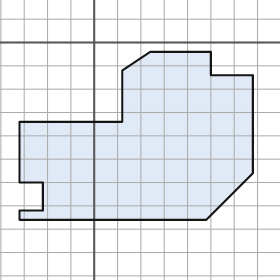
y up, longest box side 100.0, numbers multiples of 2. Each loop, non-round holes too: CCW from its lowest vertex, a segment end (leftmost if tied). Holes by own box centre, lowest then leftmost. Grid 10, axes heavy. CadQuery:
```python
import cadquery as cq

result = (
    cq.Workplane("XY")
    .moveTo(-32.0, -76.0)
    .lineTo(48.0, -76.0)
    .lineTo(68.0, -56.0)
    .lineTo(68.0, -14.0)
    .lineTo(50.0, -14.0)
    .lineTo(50.0, -4.0)
    .lineTo(24.0, -4.0)
    .lineTo(12.0, -12.0)
    .lineTo(12.0, -34.0)
    .lineTo(-32.0, -34.0)
    .lineTo(-32.0, -60.0)
    .lineTo(-22.0, -60.0)
    .lineTo(-22.0, -72.0)
    .lineTo(-32.0, -72.0)
    .close()
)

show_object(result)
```